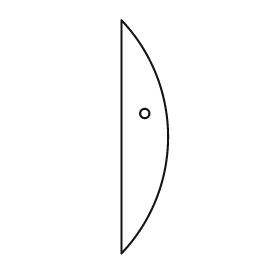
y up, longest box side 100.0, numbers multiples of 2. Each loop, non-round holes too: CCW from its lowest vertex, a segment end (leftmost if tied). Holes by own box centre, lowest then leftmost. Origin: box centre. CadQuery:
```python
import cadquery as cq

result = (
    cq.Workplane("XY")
    .moveTo(-10.0, -50.0)
    .threePointArc((10.0, 0.0), (-10.0, 50.0))
    .close()
    .moveTo(0.0, 10.0)
    .circle(2.0)
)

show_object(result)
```